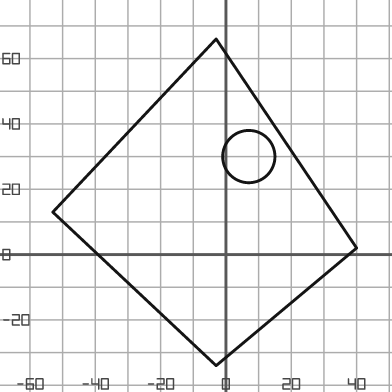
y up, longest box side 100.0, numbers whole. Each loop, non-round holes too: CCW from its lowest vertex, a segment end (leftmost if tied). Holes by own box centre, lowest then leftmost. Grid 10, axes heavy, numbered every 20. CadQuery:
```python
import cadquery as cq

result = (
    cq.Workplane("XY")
    .moveTo(-3.0, -34.0)
    .lineTo(40.0, 2.0)
    .lineTo(-3.0, 66.0)
    .lineTo(-53.0, 13.0)
    .close()
    .moveTo(7.0, 30.0)
    .circle(8.0)
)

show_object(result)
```